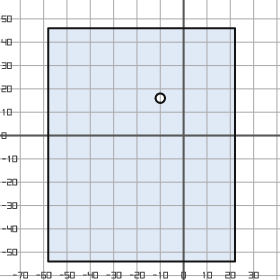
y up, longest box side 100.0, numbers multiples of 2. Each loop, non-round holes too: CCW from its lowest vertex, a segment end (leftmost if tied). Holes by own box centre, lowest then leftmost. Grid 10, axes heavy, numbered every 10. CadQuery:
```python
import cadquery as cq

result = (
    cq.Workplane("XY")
    .moveTo(-58.0, -54.0)
    .lineTo(22.0, -54.0)
    .lineTo(22.0, 46.0)
    .lineTo(-58.0, 46.0)
    .close()
    .moveTo(-10.0, 16.0)
    .circle(2.0)
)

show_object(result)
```